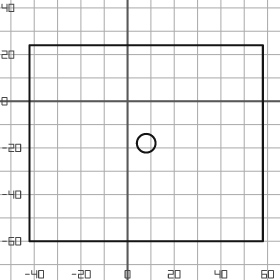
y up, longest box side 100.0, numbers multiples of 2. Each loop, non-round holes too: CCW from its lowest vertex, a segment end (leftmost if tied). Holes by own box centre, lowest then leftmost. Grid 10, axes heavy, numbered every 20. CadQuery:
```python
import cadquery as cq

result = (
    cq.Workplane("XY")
    .moveTo(-42.0, -60.0)
    .lineTo(58.0, -60.0)
    .lineTo(58.0, 24.0)
    .lineTo(-42.0, 24.0)
    .close()
    .moveTo(8.0, -18.0)
    .circle(4.0)
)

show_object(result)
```